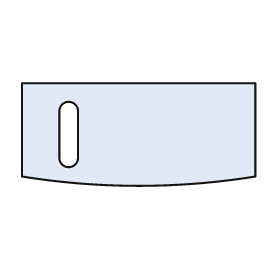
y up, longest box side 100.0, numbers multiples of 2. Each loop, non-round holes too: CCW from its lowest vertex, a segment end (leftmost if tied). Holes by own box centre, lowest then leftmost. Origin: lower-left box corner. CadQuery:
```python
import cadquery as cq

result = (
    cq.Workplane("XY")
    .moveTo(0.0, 4.0)
    .threePointArc((50.0, 0.0), (100.0, 4.0))
    .lineTo(100.0, 44.0)
    .lineTo(0.0, 44.0)
    .close()
    .moveTo(16.0, 12.0)
    .threePointArc((20.0, 8.0), (24.0, 12.0))
    .lineTo(24.0, 32.0)
    .threePointArc((20.0, 36.0), (16.0, 32.0))
    .close()
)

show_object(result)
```